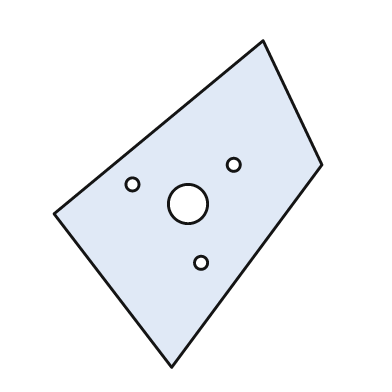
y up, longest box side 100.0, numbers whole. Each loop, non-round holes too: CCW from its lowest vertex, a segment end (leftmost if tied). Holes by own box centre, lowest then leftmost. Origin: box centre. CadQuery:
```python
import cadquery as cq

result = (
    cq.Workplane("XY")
    .moveTo(-5.0, -50.0)
    .lineTo(41.0, 12.0)
    .lineTo(23.0, 50.0)
    .lineTo(-41.0, -3.0)
    .close()
    .moveTo(4.0, -18.0)
    .circle(2.0)
    .moveTo(0.0, 0.0)
    .circle(6.0)
    .moveTo(-17.0, 6.0)
    .circle(2.0)
    .moveTo(14.0, 12.0)
    .circle(2.0)
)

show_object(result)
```